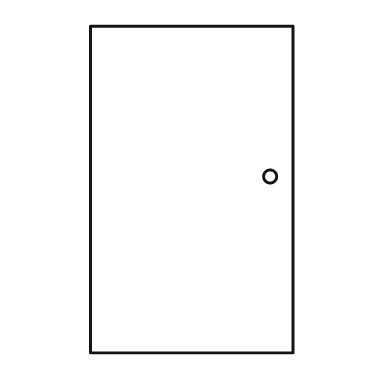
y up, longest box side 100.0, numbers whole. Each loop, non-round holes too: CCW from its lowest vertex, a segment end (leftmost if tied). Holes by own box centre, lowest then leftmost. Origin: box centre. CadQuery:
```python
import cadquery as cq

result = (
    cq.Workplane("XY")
    .moveTo(-31.0, -50.0)
    .lineTo(31.0, -50.0)
    .lineTo(31.0, 50.0)
    .lineTo(-31.0, 50.0)
    .close()
    .moveTo(24.0, 4.0)
    .circle(2.0)
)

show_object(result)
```